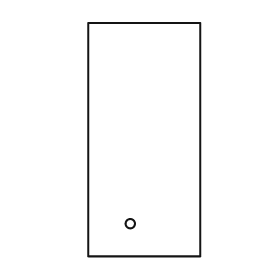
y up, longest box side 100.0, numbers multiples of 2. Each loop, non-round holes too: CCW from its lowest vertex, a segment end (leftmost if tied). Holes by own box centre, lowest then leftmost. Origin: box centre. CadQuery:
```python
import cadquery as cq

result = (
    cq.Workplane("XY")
    .moveTo(-24.0, -50.0)
    .lineTo(24.0, -50.0)
    .lineTo(24.0, 50.0)
    .lineTo(-24.0, 50.0)
    .close()
    .moveTo(-6.0, -36.0)
    .circle(2.0)
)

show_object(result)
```